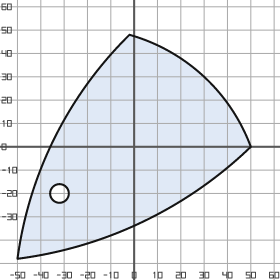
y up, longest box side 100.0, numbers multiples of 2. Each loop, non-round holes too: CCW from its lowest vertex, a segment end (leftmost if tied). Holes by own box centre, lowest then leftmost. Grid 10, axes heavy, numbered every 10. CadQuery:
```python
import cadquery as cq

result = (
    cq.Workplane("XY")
    .moveTo(-50.0, -48.0)
    .threePointArc((4.0, -32.0), (50.0, 0.0))
    .threePointArc((30.0, 30.0), (-2.0, 48.0))
    .threePointArc((-34.0, 4.0), (-50.0, -48.0))
    .close()
    .moveTo(-32.0, -20.0)
    .circle(4.0)
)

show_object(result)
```